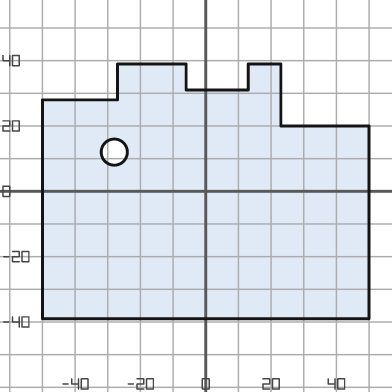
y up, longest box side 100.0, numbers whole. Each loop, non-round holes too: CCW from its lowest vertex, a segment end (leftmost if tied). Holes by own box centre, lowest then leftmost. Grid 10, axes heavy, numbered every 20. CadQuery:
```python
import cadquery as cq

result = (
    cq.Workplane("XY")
    .moveTo(-50.0, -39.0)
    .lineTo(50.0, -39.0)
    .lineTo(50.0, 20.0)
    .lineTo(23.0, 20.0)
    .lineTo(23.0, 39.0)
    .lineTo(13.0, 39.0)
    .lineTo(13.0, 31.0)
    .lineTo(-6.0, 31.0)
    .lineTo(-6.0, 39.0)
    .lineTo(-27.0, 39.0)
    .lineTo(-27.0, 28.0)
    .lineTo(-50.0, 28.0)
    .close()
    .moveTo(-28.0, 12.0)
    .circle(4.0)
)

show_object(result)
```